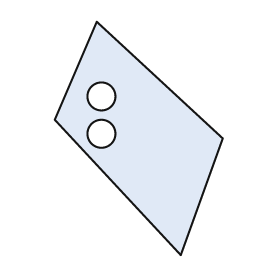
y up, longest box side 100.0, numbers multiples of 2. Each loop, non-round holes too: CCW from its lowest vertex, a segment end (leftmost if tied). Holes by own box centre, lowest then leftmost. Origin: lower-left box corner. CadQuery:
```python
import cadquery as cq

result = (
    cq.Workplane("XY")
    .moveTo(54.0, 0.0)
    .lineTo(72.0, 50.0)
    .lineTo(18.0, 100.0)
    .lineTo(0.0, 58.0)
    .close()
    .moveTo(20.0, 52.0)
    .circle(6.0)
    .moveTo(20.0, 68.0)
    .circle(6.0)
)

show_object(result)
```